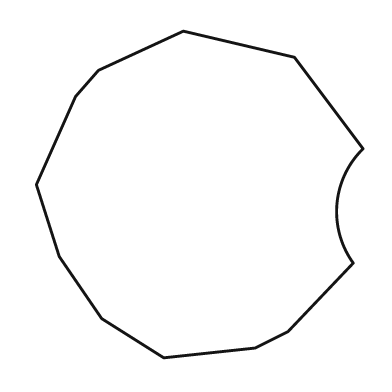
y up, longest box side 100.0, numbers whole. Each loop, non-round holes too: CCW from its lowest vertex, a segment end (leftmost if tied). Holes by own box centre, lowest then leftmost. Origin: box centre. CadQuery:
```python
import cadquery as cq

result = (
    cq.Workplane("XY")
    .moveTo(-11.0, -50.0)
    .lineTo(17.0, -47.0)
    .lineTo(27.0, -42.0)
    .lineTo(47.0, -21.0)
    .threePointArc((42.0, -3.0), (50.0, 14.0))
    .lineTo(29.0, 42.0)
    .lineTo(-5.0, 50.0)
    .lineTo(-31.0, 38.0)
    .lineTo(-38.0, 30.0)
    .lineTo(-50.0, 3.0)
    .lineTo(-43.0, -19.0)
    .lineTo(-30.0, -38.0)
    .close()
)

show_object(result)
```